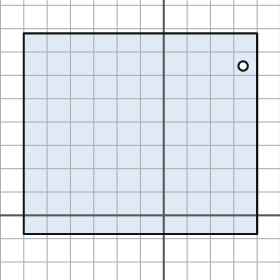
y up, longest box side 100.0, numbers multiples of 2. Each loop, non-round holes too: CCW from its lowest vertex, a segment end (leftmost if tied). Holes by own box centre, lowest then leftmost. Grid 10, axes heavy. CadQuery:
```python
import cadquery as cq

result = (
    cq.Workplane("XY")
    .moveTo(-60.0, -8.0)
    .lineTo(40.0, -8.0)
    .lineTo(40.0, 78.0)
    .lineTo(-60.0, 78.0)
    .close()
    .moveTo(34.0, 64.0)
    .circle(2.0)
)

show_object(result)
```